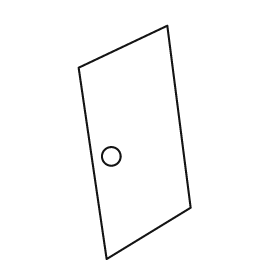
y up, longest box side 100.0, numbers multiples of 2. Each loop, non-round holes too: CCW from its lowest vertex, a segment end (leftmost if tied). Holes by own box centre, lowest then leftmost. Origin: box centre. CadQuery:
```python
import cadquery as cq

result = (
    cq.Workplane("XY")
    .moveTo(-12.0, -50.0)
    .lineTo(24.0, -28.0)
    .lineTo(14.0, 50.0)
    .lineTo(-24.0, 32.0)
    .close()
    .moveTo(-10.0, -6.0)
    .circle(4.0)
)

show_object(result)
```